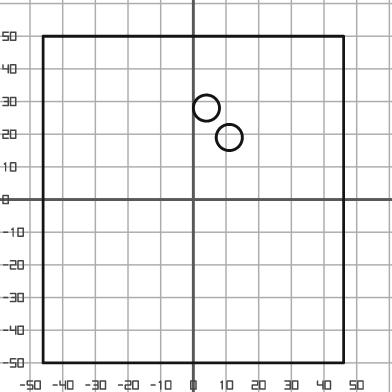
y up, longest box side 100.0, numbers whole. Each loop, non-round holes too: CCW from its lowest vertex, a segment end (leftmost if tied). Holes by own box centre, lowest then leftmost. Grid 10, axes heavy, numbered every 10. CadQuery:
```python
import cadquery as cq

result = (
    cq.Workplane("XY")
    .moveTo(-46.0, -50.0)
    .lineTo(46.0, -50.0)
    .lineTo(46.0, 50.0)
    .lineTo(-46.0, 50.0)
    .close()
    .moveTo(11.0, 19.0)
    .circle(4.0)
    .moveTo(4.0, 28.0)
    .circle(4.0)
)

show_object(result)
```